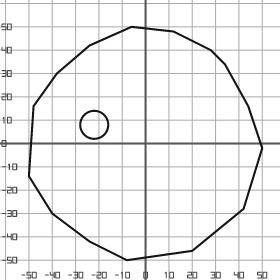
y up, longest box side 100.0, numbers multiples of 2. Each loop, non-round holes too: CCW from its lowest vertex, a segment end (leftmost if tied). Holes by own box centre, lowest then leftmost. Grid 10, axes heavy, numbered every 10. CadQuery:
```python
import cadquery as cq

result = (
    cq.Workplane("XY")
    .moveTo(-8.0, -50.0)
    .lineTo(20.0, -46.0)
    .lineTo(42.0, -28.0)
    .lineTo(50.0, -2.0)
    .lineTo(44.0, 16.0)
    .lineTo(34.0, 34.0)
    .lineTo(28.0, 40.0)
    .lineTo(12.0, 48.0)
    .lineTo(-6.0, 50.0)
    .lineTo(-24.0, 42.0)
    .lineTo(-38.0, 30.0)
    .lineTo(-48.0, 16.0)
    .lineTo(-50.0, -14.0)
    .lineTo(-40.0, -30.0)
    .lineTo(-24.0, -42.0)
    .close()
    .moveTo(-22.0, 8.0)
    .circle(6.0)
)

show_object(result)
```